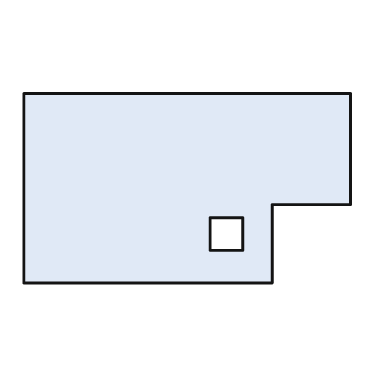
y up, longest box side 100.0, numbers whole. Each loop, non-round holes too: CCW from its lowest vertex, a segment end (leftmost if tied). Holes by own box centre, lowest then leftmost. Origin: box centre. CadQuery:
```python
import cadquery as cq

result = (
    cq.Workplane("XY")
    .moveTo(-50.0, -29.0)
    .lineTo(26.0, -29.0)
    .lineTo(26.0, -5.0)
    .lineTo(50.0, -5.0)
    .lineTo(50.0, 29.0)
    .lineTo(-50.0, 29.0)
    .close()
    .moveTo(7.0, -19.0)
    .lineTo(17.0, -19.0)
    .lineTo(17.0, -9.0)
    .lineTo(7.0, -9.0)
    .close()
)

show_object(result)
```